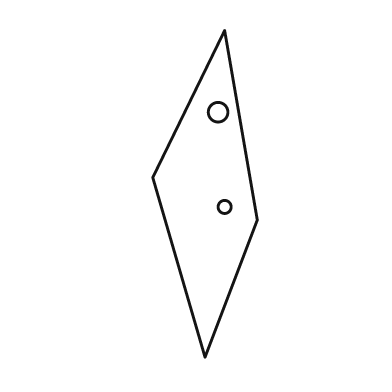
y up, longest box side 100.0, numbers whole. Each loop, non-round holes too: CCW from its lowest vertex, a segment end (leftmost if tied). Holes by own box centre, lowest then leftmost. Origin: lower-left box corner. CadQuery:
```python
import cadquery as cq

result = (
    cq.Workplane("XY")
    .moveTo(16.0, 0.0)
    .lineTo(32.0, 42.0)
    .lineTo(22.0, 100.0)
    .lineTo(0.0, 55.0)
    .close()
    .moveTo(22.0, 46.0)
    .circle(2.0)
    .moveTo(20.0, 75.0)
    .circle(3.0)
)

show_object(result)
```